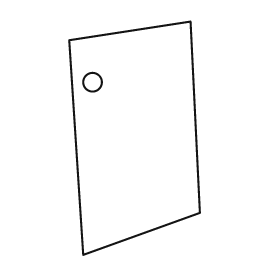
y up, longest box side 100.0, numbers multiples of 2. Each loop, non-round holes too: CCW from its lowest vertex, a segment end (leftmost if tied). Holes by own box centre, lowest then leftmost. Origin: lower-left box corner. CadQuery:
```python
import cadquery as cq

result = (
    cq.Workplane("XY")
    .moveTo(6.0, 0.0)
    .lineTo(56.0, 18.0)
    .lineTo(52.0, 100.0)
    .lineTo(0.0, 92.0)
    .close()
    .moveTo(10.0, 74.0)
    .circle(4.0)
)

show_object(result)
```